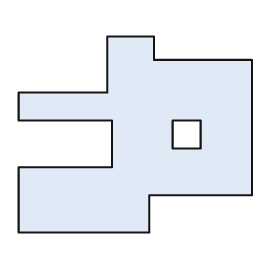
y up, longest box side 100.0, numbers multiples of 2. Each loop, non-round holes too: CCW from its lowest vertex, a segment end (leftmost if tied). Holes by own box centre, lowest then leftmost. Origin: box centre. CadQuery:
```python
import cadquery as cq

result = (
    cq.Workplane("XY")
    .moveTo(-50.0, -42.0)
    .lineTo(6.0, -42.0)
    .lineTo(6.0, -26.0)
    .lineTo(50.0, -26.0)
    .lineTo(50.0, 32.0)
    .lineTo(8.0, 32.0)
    .lineTo(8.0, 42.0)
    .lineTo(-12.0, 42.0)
    .lineTo(-12.0, 18.0)
    .lineTo(-50.0, 18.0)
    .lineTo(-50.0, 6.0)
    .lineTo(-10.0, 6.0)
    .lineTo(-10.0, -14.0)
    .lineTo(-50.0, -14.0)
    .close()
    .moveTo(16.0, -6.0)
    .lineTo(28.0, -6.0)
    .lineTo(28.0, 6.0)
    .lineTo(16.0, 6.0)
    .close()
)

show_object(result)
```